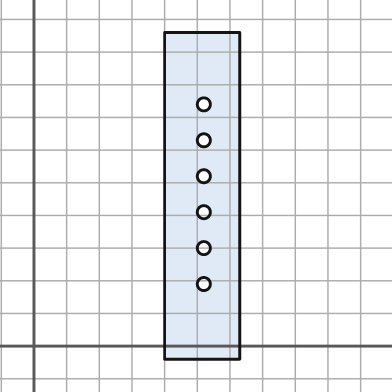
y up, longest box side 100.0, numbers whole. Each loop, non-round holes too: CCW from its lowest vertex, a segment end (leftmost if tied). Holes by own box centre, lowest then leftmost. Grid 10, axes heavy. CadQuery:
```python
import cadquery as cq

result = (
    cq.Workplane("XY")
    .moveTo(40.0, -4.0)
    .lineTo(63.0, -4.0)
    .lineTo(63.0, 96.0)
    .lineTo(40.0, 96.0)
    .close()
    .moveTo(52.0, 19.0)
    .circle(2.0)
    .moveTo(52.0, 30.0)
    .circle(2.0)
    .moveTo(52.0, 41.0)
    .circle(2.0)
    .moveTo(52.0, 52.0)
    .circle(2.0)
    .moveTo(52.0, 63.0)
    .circle(2.0)
    .moveTo(52.0, 74.0)
    .circle(2.0)
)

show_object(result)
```